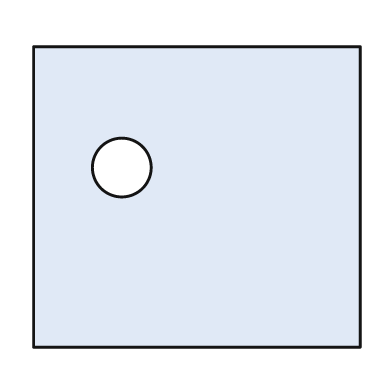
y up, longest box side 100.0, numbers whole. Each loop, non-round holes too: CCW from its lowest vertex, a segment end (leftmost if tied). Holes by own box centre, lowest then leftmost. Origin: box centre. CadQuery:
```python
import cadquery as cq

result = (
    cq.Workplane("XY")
    .moveTo(-50.0, -46.0)
    .lineTo(50.0, -46.0)
    .lineTo(50.0, 46.0)
    .lineTo(-50.0, 46.0)
    .close()
    .moveTo(-23.0, 9.0)
    .circle(9.0)
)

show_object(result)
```